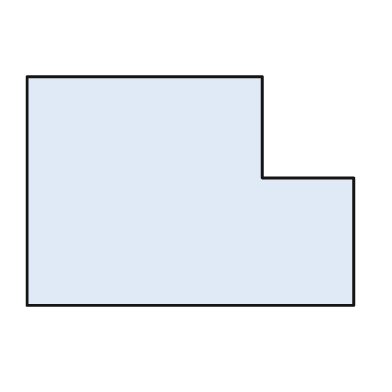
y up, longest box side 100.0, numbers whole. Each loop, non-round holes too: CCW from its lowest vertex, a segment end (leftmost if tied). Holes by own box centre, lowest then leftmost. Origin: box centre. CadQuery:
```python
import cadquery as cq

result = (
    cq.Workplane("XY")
    .moveTo(-50.0, -35.0)
    .lineTo(50.0, -35.0)
    .lineTo(50.0, 4.0)
    .lineTo(22.0, 4.0)
    .lineTo(22.0, 35.0)
    .lineTo(-50.0, 35.0)
    .close()
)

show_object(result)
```